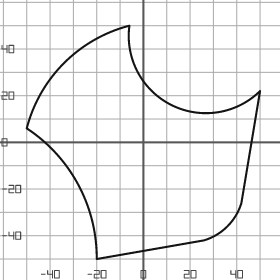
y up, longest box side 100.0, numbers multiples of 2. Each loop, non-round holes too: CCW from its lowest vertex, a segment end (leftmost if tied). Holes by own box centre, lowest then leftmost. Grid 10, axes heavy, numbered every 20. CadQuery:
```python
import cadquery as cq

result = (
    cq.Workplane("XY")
    .moveTo(-20.0, -50.0)
    .lineTo(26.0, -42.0)
    .threePointArc((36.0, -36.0), (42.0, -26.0))
    .lineTo(50.0, 22.0)
    .threePointArc((12.0, 16.0), (-6.0, 50.0))
    .threePointArc((-34.0, 34.0), (-50.0, 6.0))
    .threePointArc((-28.0, -18.0), (-20.0, -50.0))
    .close()
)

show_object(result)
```